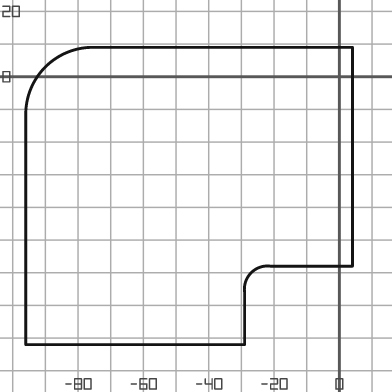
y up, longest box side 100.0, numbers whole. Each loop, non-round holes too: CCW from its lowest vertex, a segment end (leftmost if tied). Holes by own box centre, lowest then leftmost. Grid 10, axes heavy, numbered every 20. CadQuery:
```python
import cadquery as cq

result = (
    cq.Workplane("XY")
    .moveTo(-96.0, -82.0)
    .lineTo(-29.0, -82.0)
    .lineTo(-29.0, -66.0)
    .threePointArc((-27.0, -60.0), (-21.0, -58.0))
    .lineTo(4.0, -58.0)
    .lineTo(4.0, 9.0)
    .lineTo(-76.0, 9.0)
    .threePointArc((-90.0, 3.0), (-96.0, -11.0))
    .close()
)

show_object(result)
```